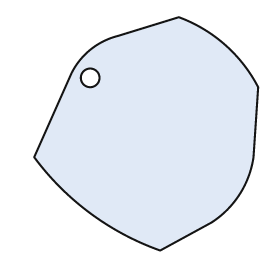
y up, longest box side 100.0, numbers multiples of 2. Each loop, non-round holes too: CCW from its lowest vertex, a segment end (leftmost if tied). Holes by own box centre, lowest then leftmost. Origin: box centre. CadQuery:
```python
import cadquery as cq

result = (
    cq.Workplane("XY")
    .moveTo(6.0, -50.0)
    .lineTo(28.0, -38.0)
    .threePointArc((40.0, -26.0), (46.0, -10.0))
    .lineTo(48.0, 20.0)
    .threePointArc((34.0, 38.0), (14.0, 50.0))
    .lineTo(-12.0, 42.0)
    .threePointArc((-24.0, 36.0), (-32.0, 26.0))
    .lineTo(-48.0, -10.0)
    .threePointArc((-24.0, -34.0), (6.0, -50.0))
    .close()
    .moveTo(-24.0, 24.0)
    .circle(4.0)
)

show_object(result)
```